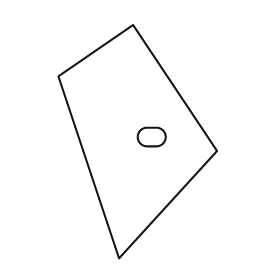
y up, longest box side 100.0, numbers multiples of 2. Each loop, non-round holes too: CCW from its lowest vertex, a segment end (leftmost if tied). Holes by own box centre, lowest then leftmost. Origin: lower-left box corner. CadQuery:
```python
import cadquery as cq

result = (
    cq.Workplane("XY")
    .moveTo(26.0, 0.0)
    .lineTo(68.0, 46.0)
    .lineTo(32.0, 100.0)
    .lineTo(0.0, 78.0)
    .close()
    .moveTo(38.0, 48.0)
    .lineTo(42.0, 48.0)
    .threePointArc((46.0, 52.0), (42.0, 56.0))
    .lineTo(38.0, 56.0)
    .threePointArc((34.0, 52.0), (38.0, 48.0))
    .close()
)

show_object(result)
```